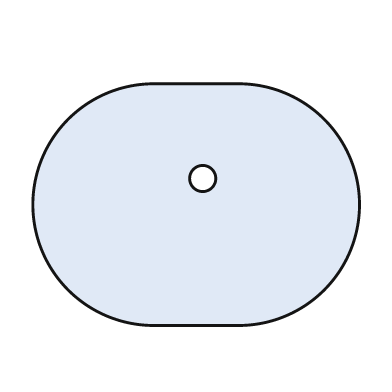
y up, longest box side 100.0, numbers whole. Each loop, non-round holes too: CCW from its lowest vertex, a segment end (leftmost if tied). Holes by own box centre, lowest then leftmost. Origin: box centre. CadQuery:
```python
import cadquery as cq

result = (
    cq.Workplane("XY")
    .moveTo(-13.0, -37.0)
    .lineTo(13.0, -37.0)
    .threePointArc((50.0, 0.0), (13.0, 37.0))
    .lineTo(-13.0, 37.0)
    .threePointArc((-50.0, 0.0), (-13.0, -37.0))
    .close()
    .moveTo(2.0, 8.0)
    .circle(4.0)
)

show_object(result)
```